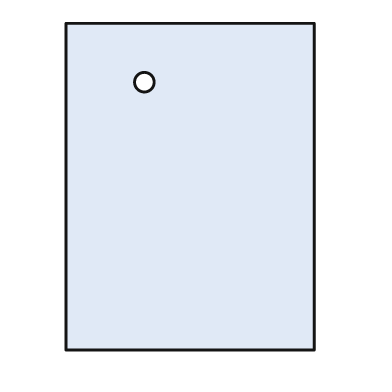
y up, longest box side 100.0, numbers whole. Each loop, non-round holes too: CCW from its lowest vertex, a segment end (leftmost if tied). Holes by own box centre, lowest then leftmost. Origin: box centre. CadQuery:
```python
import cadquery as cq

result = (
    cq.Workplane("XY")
    .moveTo(-38.0, -50.0)
    .lineTo(38.0, -50.0)
    .lineTo(38.0, 50.0)
    .lineTo(-38.0, 50.0)
    .close()
    .moveTo(-14.0, 32.0)
    .circle(3.0)
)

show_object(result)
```